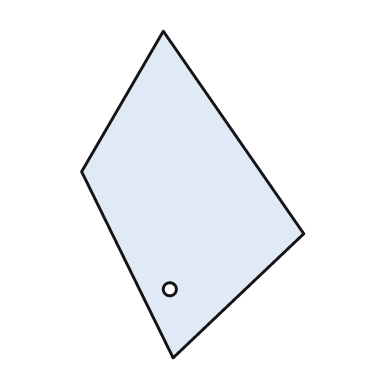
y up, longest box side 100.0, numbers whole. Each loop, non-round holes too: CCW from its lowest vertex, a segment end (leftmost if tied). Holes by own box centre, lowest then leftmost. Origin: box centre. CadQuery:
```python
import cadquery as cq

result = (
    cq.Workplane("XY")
    .moveTo(-6.0, -50.0)
    .lineTo(34.0, -12.0)
    .lineTo(-9.0, 50.0)
    .lineTo(-34.0, 7.0)
    .close()
    .moveTo(-7.0, -29.0)
    .circle(2.0)
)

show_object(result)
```